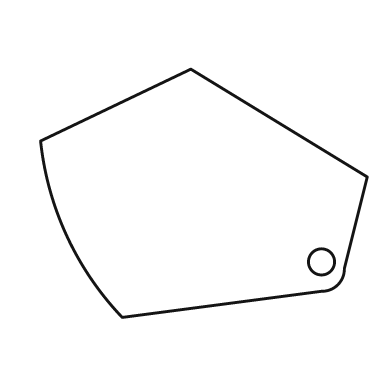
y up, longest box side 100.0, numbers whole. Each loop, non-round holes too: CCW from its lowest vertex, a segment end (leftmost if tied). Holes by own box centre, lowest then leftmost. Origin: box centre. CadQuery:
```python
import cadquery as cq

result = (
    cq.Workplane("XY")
    .moveTo(-25.0, -38.0)
    .lineTo(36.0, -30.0)
    .threePointArc((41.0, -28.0), (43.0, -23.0))
    .lineTo(50.0, 5.0)
    .lineTo(-4.0, 38.0)
    .lineTo(-50.0, 16.0)
    .threePointArc((-42.0, -13.0), (-25.0, -38.0))
    .close()
    .moveTo(36.0, -21.0)
    .circle(4.0)
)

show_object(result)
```